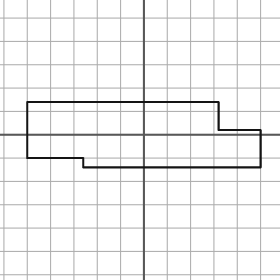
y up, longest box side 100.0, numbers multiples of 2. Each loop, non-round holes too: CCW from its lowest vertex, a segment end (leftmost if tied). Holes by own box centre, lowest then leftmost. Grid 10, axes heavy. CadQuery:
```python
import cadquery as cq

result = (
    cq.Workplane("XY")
    .moveTo(-26.0, -14.0)
    .lineTo(50.0, -14.0)
    .lineTo(50.0, 2.0)
    .lineTo(32.0, 2.0)
    .lineTo(32.0, 14.0)
    .lineTo(-50.0, 14.0)
    .lineTo(-50.0, -10.0)
    .lineTo(-26.0, -10.0)
    .close()
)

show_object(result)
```